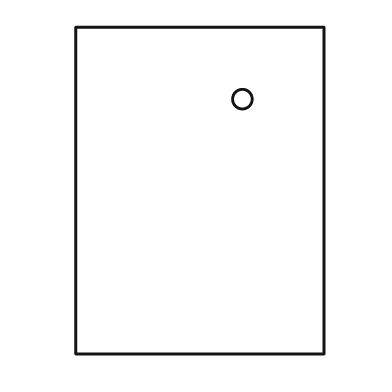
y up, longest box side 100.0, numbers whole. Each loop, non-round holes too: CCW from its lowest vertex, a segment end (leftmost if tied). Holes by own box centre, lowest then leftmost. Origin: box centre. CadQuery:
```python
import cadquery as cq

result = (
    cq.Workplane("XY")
    .moveTo(-38.0, -50.0)
    .lineTo(38.0, -50.0)
    .lineTo(38.0, 50.0)
    .lineTo(-38.0, 50.0)
    .close()
    .moveTo(13.0, 28.0)
    .circle(3.0)
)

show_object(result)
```